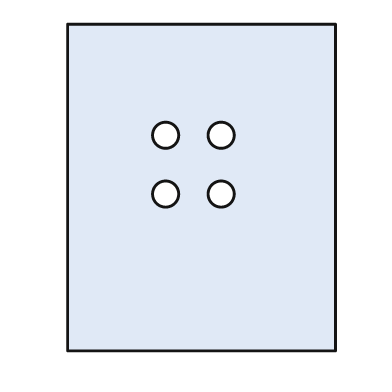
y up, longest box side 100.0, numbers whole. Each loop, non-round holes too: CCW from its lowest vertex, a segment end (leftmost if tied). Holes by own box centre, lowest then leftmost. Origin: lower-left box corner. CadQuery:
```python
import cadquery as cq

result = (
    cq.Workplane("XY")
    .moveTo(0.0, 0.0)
    .lineTo(82.0, 0.0)
    .lineTo(82.0, 100.0)
    .lineTo(0.0, 100.0)
    .close()
    .moveTo(30.0, 48.0)
    .circle(4.0)
    .moveTo(47.0, 48.0)
    .circle(4.0)
    .moveTo(30.0, 66.0)
    .circle(4.0)
    .moveTo(47.0, 66.0)
    .circle(4.0)
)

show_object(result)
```